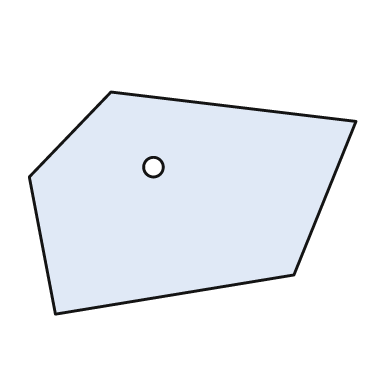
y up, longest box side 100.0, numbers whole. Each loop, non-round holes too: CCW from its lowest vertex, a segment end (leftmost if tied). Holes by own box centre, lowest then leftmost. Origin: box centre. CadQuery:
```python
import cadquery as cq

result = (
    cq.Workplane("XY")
    .moveTo(-42.0, -34.0)
    .lineTo(31.0, -22.0)
    .lineTo(50.0, 25.0)
    .lineTo(-25.0, 34.0)
    .lineTo(-50.0, 8.0)
    .close()
    .moveTo(-12.0, 11.0)
    .circle(3.0)
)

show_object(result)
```